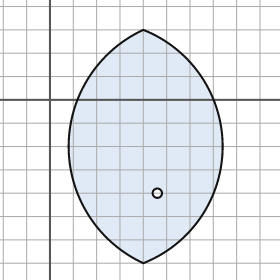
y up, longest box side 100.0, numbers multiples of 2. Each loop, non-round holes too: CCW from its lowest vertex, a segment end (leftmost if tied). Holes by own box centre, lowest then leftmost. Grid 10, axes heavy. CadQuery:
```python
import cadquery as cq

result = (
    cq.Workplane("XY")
    .moveTo(40.0, -70.0)
    .threePointArc((74.0, -20.0), (40.0, 30.0))
    .threePointArc((8.0, -20.0), (40.0, -70.0))
    .close()
    .moveTo(46.0, -40.0)
    .circle(2.0)
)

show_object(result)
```